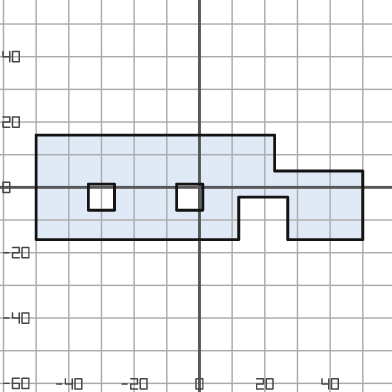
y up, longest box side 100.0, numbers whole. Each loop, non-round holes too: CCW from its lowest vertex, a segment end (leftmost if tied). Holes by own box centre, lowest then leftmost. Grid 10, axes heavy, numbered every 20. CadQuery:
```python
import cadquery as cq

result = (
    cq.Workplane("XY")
    .moveTo(-50.0, -16.0)
    .lineTo(12.0, -16.0)
    .lineTo(12.0, -3.0)
    .lineTo(27.0, -3.0)
    .lineTo(27.0, -16.0)
    .lineTo(50.0, -16.0)
    .lineTo(50.0, 5.0)
    .lineTo(23.0, 5.0)
    .lineTo(23.0, 16.0)
    .lineTo(-50.0, 16.0)
    .close()
    .moveTo(-34.0, -7.0)
    .lineTo(-26.0, -7.0)
    .lineTo(-26.0, 1.0)
    .lineTo(-34.0, 1.0)
    .close()
    .moveTo(-7.0, -7.0)
    .lineTo(1.0, -7.0)
    .lineTo(1.0, 1.0)
    .lineTo(-7.0, 1.0)
    .close()
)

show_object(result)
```